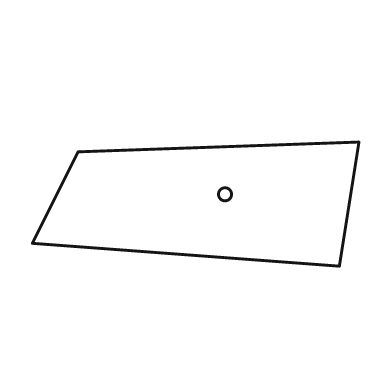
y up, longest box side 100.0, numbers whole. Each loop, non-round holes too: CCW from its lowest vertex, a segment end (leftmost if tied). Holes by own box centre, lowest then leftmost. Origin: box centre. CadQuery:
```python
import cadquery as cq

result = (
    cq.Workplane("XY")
    .moveTo(44.0, -19.0)
    .lineTo(50.0, 19.0)
    .lineTo(-36.0, 16.0)
    .lineTo(-50.0, -12.0)
    .close()
    .moveTo(9.0, 3.0)
    .circle(2.0)
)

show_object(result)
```